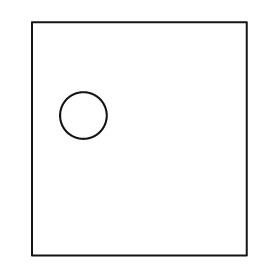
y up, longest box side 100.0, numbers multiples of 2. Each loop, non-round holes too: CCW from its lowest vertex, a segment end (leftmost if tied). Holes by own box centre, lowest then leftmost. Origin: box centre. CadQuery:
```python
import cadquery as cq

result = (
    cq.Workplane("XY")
    .moveTo(-46.0, -50.0)
    .lineTo(46.0, -50.0)
    .lineTo(46.0, 50.0)
    .lineTo(-46.0, 50.0)
    .close()
    .moveTo(-24.0, 10.0)
    .circle(10.0)
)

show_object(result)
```